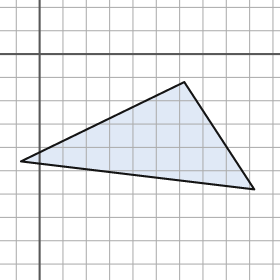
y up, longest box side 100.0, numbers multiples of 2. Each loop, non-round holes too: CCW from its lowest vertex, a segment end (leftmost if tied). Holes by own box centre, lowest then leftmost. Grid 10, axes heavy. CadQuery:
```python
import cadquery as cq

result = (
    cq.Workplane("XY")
    .moveTo(92.0, -58.0)
    .lineTo(62.0, -12.0)
    .lineTo(-8.0, -46.0)
    .close()
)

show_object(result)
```